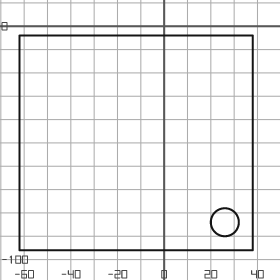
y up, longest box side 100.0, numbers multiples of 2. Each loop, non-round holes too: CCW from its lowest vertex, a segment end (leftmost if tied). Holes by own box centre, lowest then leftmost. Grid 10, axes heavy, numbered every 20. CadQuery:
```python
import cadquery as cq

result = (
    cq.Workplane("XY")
    .moveTo(-62.0, -96.0)
    .lineTo(38.0, -96.0)
    .lineTo(38.0, -4.0)
    .lineTo(-62.0, -4.0)
    .close()
    .moveTo(26.0, -84.0)
    .circle(6.0)
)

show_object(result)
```